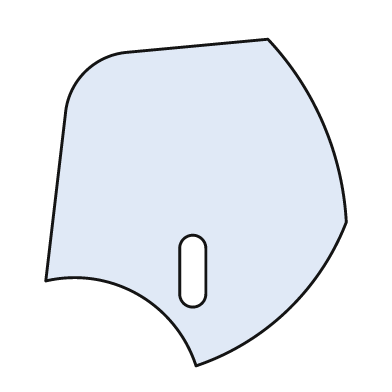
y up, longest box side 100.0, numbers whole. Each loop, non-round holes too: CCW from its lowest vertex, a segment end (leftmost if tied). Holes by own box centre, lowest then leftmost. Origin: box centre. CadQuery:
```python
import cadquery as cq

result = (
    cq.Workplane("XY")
    .moveTo(0.0, -50.0)
    .threePointArc((28.0, -33.0), (46.0, -6.0))
    .threePointArc((39.0, 24.0), (22.0, 50.0))
    .lineTo(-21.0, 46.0)
    .threePointArc((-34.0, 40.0), (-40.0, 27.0))
    .lineTo(-46.0, -24.0)
    .threePointArc((-18.0, -28.0), (0.0, -50.0))
    .close()
    .moveTo(-5.0, -28.0)
    .threePointArc((-1.0, -32.0), (3.0, -28.0))
    .lineTo(3.0, -14.0)
    .threePointArc((-1.0, -10.0), (-5.0, -14.0))
    .close()
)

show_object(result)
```